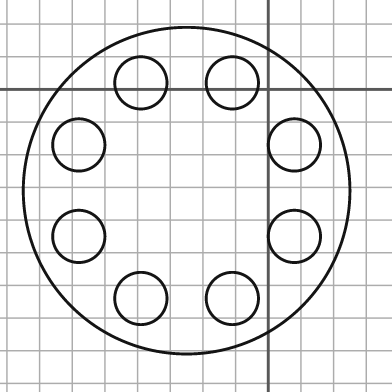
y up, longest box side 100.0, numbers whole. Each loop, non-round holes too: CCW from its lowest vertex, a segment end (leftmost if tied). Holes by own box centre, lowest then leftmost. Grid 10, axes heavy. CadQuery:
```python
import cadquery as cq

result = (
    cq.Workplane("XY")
    .moveTo(-25.0, -31.0)
    .circle(50.0)
    .moveTo(-39.0, -64.0)
    .circle(8.0)
    .moveTo(-11.0, -64.0)
    .circle(8.0)
    .moveTo(-58.0, -45.0)
    .circle(8.0)
    .moveTo(8.0, -45.0)
    .circle(8.0)
    .moveTo(-58.0, -17.0)
    .circle(8.0)
    .moveTo(8.0, -17.0)
    .circle(8.0)
    .moveTo(-39.0, 2.0)
    .circle(8.0)
    .moveTo(-11.0, 2.0)
    .circle(8.0)
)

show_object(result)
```